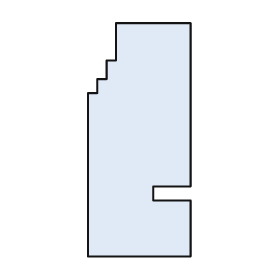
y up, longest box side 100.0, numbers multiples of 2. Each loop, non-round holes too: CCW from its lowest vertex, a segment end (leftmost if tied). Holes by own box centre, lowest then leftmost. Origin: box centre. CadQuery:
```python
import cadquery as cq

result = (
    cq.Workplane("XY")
    .moveTo(-22.0, -50.0)
    .lineTo(22.0, -50.0)
    .lineTo(22.0, -26.0)
    .lineTo(6.0, -26.0)
    .lineTo(6.0, -20.0)
    .lineTo(22.0, -20.0)
    .lineTo(22.0, 50.0)
    .lineTo(-10.0, 50.0)
    .lineTo(-10.0, 34.0)
    .lineTo(-14.0, 34.0)
    .lineTo(-14.0, 26.0)
    .lineTo(-18.0, 26.0)
    .lineTo(-18.0, 20.0)
    .lineTo(-22.0, 20.0)
    .close()
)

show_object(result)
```